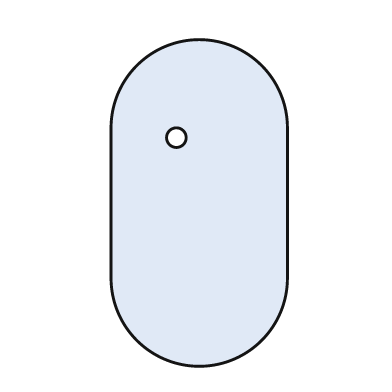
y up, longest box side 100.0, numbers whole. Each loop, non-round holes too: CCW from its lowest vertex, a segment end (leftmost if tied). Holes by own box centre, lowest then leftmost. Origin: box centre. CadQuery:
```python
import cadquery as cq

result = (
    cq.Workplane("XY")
    .moveTo(-27.0, -23.0)
    .threePointArc((0.0, -50.0), (27.0, -23.0))
    .lineTo(27.0, 23.0)
    .threePointArc((0.0, 50.0), (-27.0, 23.0))
    .close()
    .moveTo(-7.0, 20.0)
    .circle(3.0)
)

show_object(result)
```